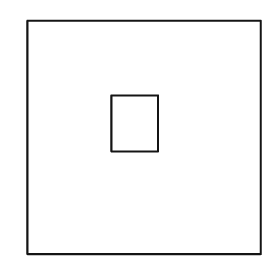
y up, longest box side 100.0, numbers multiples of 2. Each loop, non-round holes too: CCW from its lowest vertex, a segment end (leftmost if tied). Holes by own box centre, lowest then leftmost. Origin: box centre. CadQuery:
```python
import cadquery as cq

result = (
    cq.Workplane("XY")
    .moveTo(-50.0, -50.0)
    .lineTo(50.0, -50.0)
    .lineTo(50.0, 50.0)
    .lineTo(-50.0, 50.0)
    .close()
    .moveTo(-14.0, -6.0)
    .lineTo(6.0, -6.0)
    .lineTo(6.0, 18.0)
    .lineTo(-14.0, 18.0)
    .close()
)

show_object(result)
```